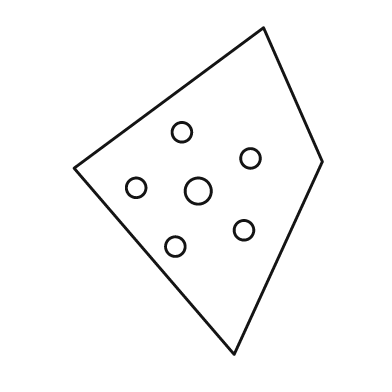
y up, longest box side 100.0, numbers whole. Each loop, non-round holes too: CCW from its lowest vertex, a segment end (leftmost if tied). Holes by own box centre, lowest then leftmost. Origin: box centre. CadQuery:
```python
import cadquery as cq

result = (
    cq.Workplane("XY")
    .moveTo(11.0, -50.0)
    .lineTo(38.0, 9.0)
    .lineTo(20.0, 50.0)
    .lineTo(-38.0, 7.0)
    .close()
    .moveTo(-7.0, -17.0)
    .circle(3.0)
    .moveTo(14.0, -12.0)
    .circle(3.0)
    .moveTo(0.0, 0.0)
    .circle(4.0)
    .moveTo(-19.0, 1.0)
    .circle(3.0)
    .moveTo(16.0, 10.0)
    .circle(3.0)
    .moveTo(-5.0, 18.0)
    .circle(3.0)
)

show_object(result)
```